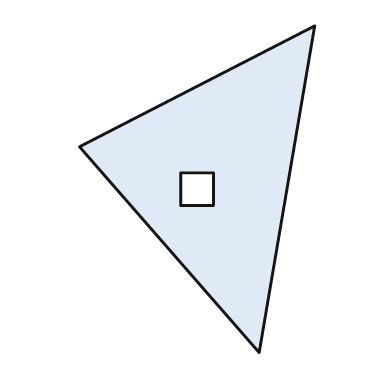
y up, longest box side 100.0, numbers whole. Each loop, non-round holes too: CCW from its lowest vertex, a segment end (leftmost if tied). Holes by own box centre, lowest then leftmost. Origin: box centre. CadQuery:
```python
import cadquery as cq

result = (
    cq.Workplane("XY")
    .moveTo(19.0, -50.0)
    .lineTo(36.0, 50.0)
    .lineTo(-36.0, 13.0)
    .close()
    .moveTo(-5.0, -5.0)
    .lineTo(5.0, -5.0)
    .lineTo(5.0, 5.0)
    .lineTo(-5.0, 5.0)
    .close()
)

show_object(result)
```